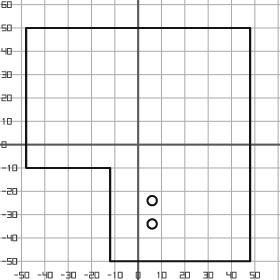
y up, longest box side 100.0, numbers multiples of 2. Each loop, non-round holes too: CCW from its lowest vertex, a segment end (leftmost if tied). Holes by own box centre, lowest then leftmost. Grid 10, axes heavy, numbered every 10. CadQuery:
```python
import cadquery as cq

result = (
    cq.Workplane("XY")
    .moveTo(-12.0, -50.0)
    .lineTo(48.0, -50.0)
    .lineTo(48.0, 50.0)
    .lineTo(-48.0, 50.0)
    .lineTo(-48.0, -10.0)
    .lineTo(-12.0, -10.0)
    .close()
    .moveTo(6.0, -34.0)
    .circle(2.0)
    .moveTo(6.0, -24.0)
    .circle(2.0)
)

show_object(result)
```